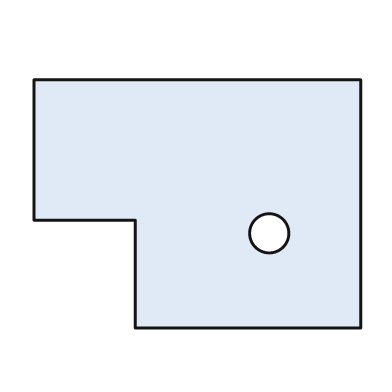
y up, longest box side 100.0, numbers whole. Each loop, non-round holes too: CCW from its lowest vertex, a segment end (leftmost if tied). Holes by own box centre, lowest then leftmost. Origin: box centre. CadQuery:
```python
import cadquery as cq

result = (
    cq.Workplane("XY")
    .moveTo(-19.0, -38.0)
    .lineTo(50.0, -38.0)
    .lineTo(50.0, 38.0)
    .lineTo(-50.0, 38.0)
    .lineTo(-50.0, -5.0)
    .lineTo(-19.0, -5.0)
    .close()
    .moveTo(22.0, -9.0)
    .circle(6.0)
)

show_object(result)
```